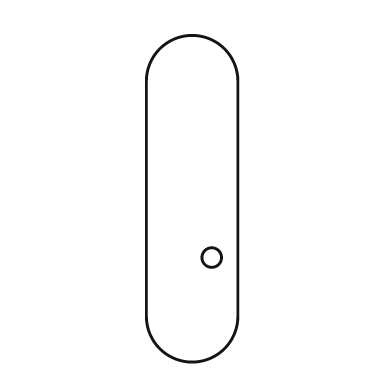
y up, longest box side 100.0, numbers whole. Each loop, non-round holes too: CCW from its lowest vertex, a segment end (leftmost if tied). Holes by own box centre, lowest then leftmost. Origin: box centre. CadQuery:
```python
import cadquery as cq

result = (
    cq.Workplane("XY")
    .moveTo(-14.0, -36.0)
    .threePointArc((0.0, -50.0), (14.0, -36.0))
    .lineTo(14.0, 36.0)
    .threePointArc((0.0, 50.0), (-14.0, 36.0))
    .close()
    .moveTo(6.0, -18.0)
    .circle(3.0)
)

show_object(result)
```